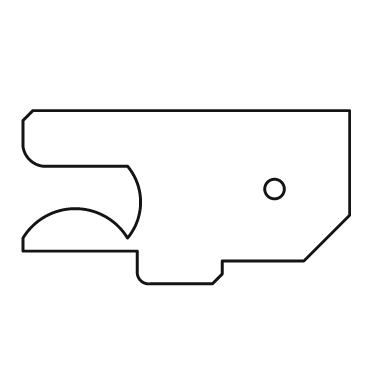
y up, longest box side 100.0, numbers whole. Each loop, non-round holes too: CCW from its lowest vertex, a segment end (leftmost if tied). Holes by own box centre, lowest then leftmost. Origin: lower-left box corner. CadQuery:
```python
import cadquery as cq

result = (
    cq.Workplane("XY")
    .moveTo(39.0, 0.0)
    .lineTo(58.0, 0.0)
    .lineTo(61.0, 3.0)
    .lineTo(61.0, 7.0)
    .lineTo(86.0, 7.0)
    .lineTo(100.0, 21.0)
    .lineTo(100.0, 53.0)
    .lineTo(3.0, 53.0)
    .lineTo(0.0, 50.0)
    .lineTo(0.0, 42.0)
    .threePointArc((2.0, 38.0), (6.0, 36.0))
    .lineTo(32.0, 36.0)
    .threePointArc((36.0, 25.0), (32.0, 14.0))
    .threePointArc((16.0, 23.0), (0.0, 14.0))
    .lineTo(0.0, 10.0)
    .lineTo(35.0, 10.0)
    .lineTo(35.0, 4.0)
    .threePointArc((36.0, 1.0), (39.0, 0.0))
    .close()
    .moveTo(77.0, 29.0)
    .circle(3.0)
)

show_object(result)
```